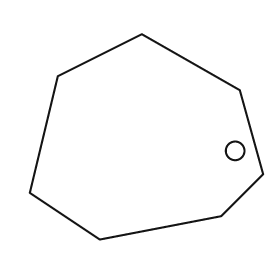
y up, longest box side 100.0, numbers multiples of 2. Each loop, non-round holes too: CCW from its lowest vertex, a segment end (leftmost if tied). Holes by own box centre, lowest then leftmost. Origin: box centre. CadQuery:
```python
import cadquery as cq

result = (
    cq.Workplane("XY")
    .moveTo(-20.0, -44.0)
    .lineTo(32.0, -34.0)
    .lineTo(50.0, -16.0)
    .lineTo(40.0, 20.0)
    .lineTo(-2.0, 44.0)
    .lineTo(-38.0, 26.0)
    .lineTo(-50.0, -24.0)
    .close()
    .moveTo(38.0, -6.0)
    .circle(4.0)
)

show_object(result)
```